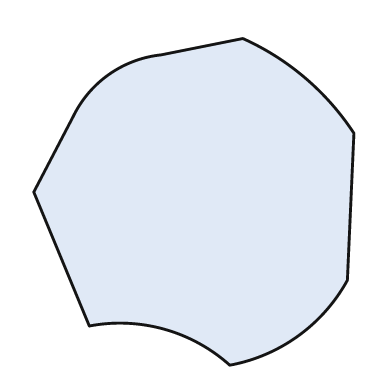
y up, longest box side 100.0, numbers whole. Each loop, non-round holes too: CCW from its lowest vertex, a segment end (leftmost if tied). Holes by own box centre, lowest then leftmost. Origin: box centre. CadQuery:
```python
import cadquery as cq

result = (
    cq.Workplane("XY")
    .moveTo(11.0, -50.0)
    .threePointArc((32.0, -41.0), (47.0, -24.0))
    .lineTo(49.0, 21.0)
    .threePointArc((34.0, 38.0), (15.0, 50.0))
    .lineTo(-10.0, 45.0)
    .threePointArc((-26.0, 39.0), (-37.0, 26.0))
    .lineTo(-49.0, 3.0)
    .lineTo(-32.0, -38.0)
    .threePointArc((-9.0, -39.0), (11.0, -50.0))
    .close()
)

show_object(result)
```